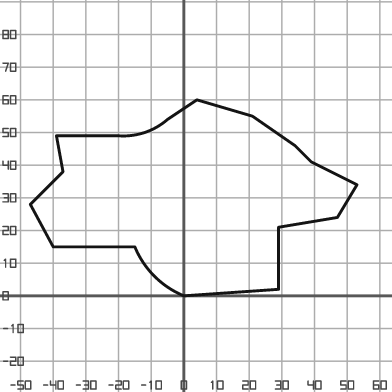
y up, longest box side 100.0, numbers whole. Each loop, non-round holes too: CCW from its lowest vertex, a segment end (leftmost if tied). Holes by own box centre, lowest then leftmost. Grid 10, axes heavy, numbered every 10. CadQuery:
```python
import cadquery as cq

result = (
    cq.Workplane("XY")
    .moveTo(0.0, 0.0)
    .lineTo(29.0, 2.0)
    .lineTo(29.0, 21.0)
    .lineTo(47.0, 24.0)
    .lineTo(53.0, 34.0)
    .lineTo(39.0, 41.0)
    .lineTo(34.0, 46.0)
    .lineTo(21.0, 55.0)
    .lineTo(4.0, 60.0)
    .lineTo(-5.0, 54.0)
    .threePointArc((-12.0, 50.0), (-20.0, 49.0))
    .lineTo(-39.0, 49.0)
    .lineTo(-37.0, 38.0)
    .lineTo(-47.0, 28.0)
    .lineTo(-40.0, 15.0)
    .lineTo(-15.0, 15.0)
    .threePointArc((-9.0, 6.0), (0.0, 0.0))
    .close()
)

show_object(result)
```